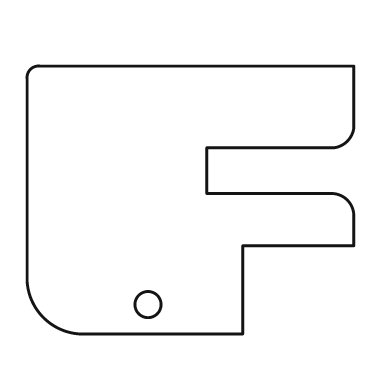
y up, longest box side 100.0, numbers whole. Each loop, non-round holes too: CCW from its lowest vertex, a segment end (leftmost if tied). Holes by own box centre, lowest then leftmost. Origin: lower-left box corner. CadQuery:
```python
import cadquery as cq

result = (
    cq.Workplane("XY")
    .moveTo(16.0, 0.0)
    .lineTo(66.0, 0.0)
    .lineTo(66.0, 27.0)
    .lineTo(100.0, 27.0)
    .lineTo(100.0, 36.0)
    .threePointArc((98.0, 41.0), (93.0, 43.0))
    .lineTo(55.0, 43.0)
    .lineTo(55.0, 57.0)
    .lineTo(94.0, 57.0)
    .threePointArc((98.0, 59.0), (100.0, 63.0))
    .lineTo(100.0, 82.0)
    .lineTo(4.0, 82.0)
    .threePointArc((1.0, 81.0), (0.0, 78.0))
    .lineTo(0.0, 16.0)
    .threePointArc((5.0, 5.0), (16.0, 0.0))
    .close()
    .moveTo(37.0, 9.0)
    .circle(4.0)
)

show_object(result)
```